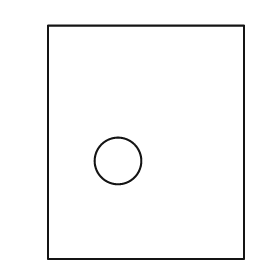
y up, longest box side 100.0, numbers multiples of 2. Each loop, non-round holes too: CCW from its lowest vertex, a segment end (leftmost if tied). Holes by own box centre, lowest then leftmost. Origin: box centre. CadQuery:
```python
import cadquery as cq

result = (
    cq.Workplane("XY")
    .moveTo(-42.0, -50.0)
    .lineTo(42.0, -50.0)
    .lineTo(42.0, 50.0)
    .lineTo(-42.0, 50.0)
    .close()
    .moveTo(-12.0, -8.0)
    .circle(10.0)
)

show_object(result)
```